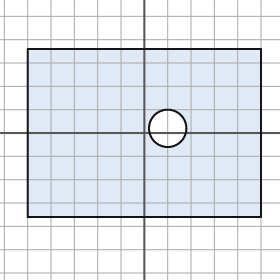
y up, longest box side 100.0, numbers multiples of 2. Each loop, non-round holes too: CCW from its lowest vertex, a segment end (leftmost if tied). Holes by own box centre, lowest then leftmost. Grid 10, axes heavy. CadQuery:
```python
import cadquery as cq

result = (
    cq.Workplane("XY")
    .moveTo(-50.0, -36.0)
    .lineTo(50.0, -36.0)
    .lineTo(50.0, 36.0)
    .lineTo(-50.0, 36.0)
    .close()
    .moveTo(10.0, 2.0)
    .circle(8.0)
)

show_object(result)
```